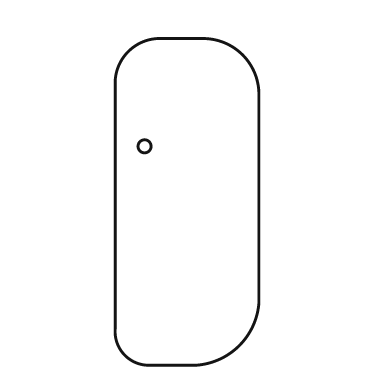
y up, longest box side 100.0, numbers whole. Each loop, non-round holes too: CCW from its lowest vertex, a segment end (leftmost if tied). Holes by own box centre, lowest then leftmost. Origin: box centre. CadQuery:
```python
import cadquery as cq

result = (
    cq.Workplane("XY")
    .moveTo(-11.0, -50.0)
    .lineTo(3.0, -50.0)
    .threePointArc((16.0, -44.0), (22.0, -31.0))
    .lineTo(22.0, 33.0)
    .threePointArc((17.0, 45.0), (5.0, 50.0))
    .lineTo(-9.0, 50.0)
    .threePointArc((-18.0, 46.0), (-22.0, 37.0))
    .lineTo(-22.0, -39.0)
    .threePointArc((-19.0, -47.0), (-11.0, -50.0))
    .close()
    .moveTo(-13.0, 17.0)
    .circle(2.0)
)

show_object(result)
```